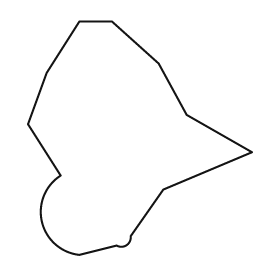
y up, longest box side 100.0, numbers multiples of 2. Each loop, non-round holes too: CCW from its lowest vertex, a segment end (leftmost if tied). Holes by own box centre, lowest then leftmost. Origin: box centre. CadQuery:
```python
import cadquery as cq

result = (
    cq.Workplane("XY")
    .moveTo(-26.0, -50.0)
    .lineTo(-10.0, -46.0)
    .threePointArc((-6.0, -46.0), (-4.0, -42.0))
    .lineTo(10.0, -22.0)
    .lineTo(48.0, -6.0)
    .lineTo(20.0, 10.0)
    .lineTo(8.0, 32.0)
    .lineTo(-12.0, 50.0)
    .lineTo(-26.0, 50.0)
    .lineTo(-40.0, 28.0)
    .lineTo(-48.0, 6.0)
    .lineTo(-34.0, -16.0)
    .threePointArc((-42.0, -36.0), (-26.0, -50.0))
    .close()
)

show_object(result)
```